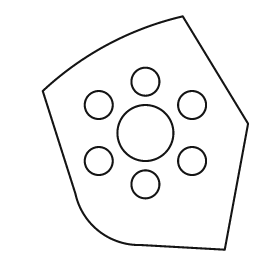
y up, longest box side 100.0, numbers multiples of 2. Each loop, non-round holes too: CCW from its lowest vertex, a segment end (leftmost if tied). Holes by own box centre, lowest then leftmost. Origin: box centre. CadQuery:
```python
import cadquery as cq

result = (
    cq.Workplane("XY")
    .moveTo(34.0, -50.0)
    .lineTo(44.0, 4.0)
    .lineTo(16.0, 50.0)
    .threePointArc((-16.0, 38.0), (-44.0, 18.0))
    .lineTo(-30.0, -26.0)
    .threePointArc((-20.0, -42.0), (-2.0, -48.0))
    .close()
    .moveTo(0.0, -22.0)
    .circle(6.0)
    .moveTo(-20.0, -12.0)
    .circle(6.0)
    .moveTo(20.0, -12.0)
    .circle(6.0)
    .moveTo(0.0, 0.0)
    .circle(12.0)
    .moveTo(-20.0, 12.0)
    .circle(6.0)
    .moveTo(20.0, 12.0)
    .circle(6.0)
    .moveTo(0.0, 22.0)
    .circle(6.0)
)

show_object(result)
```